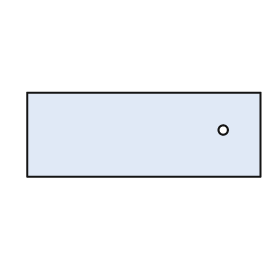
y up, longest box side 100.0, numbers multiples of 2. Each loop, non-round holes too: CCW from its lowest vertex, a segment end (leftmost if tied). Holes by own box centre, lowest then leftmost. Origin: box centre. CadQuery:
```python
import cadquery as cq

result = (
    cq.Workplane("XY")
    .moveTo(-50.0, -18.0)
    .lineTo(50.0, -18.0)
    .lineTo(50.0, 18.0)
    .lineTo(-50.0, 18.0)
    .close()
    .moveTo(34.0, 2.0)
    .circle(2.0)
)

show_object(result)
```